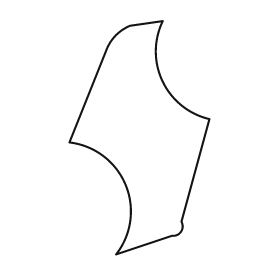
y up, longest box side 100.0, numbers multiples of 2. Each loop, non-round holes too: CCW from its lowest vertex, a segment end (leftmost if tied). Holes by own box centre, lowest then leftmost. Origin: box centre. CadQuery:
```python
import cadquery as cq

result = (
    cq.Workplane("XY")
    .moveTo(-10.0, -50.0)
    .lineTo(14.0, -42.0)
    .threePointArc((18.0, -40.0), (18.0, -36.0))
    .lineTo(30.0, 8.0)
    .threePointArc((10.0, 24.0), (10.0, 50.0))
    .lineTo(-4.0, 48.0)
    .threePointArc((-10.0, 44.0), (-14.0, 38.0))
    .lineTo(-30.0, -2.0)
    .threePointArc((-6.0, -20.0), (-10.0, -50.0))
    .close()
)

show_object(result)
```